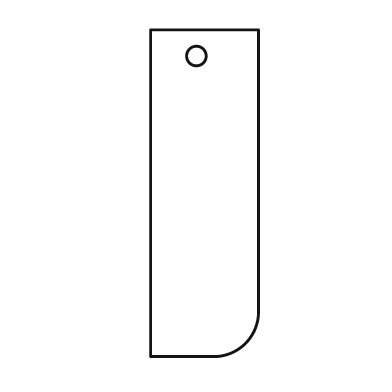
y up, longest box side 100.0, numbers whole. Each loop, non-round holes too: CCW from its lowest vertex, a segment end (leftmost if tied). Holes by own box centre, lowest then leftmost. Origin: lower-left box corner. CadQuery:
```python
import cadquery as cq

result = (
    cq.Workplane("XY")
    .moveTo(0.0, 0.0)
    .lineTo(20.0, 0.0)
    .threePointArc((29.0, 4.0), (33.0, 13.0))
    .lineTo(33.0, 100.0)
    .lineTo(0.0, 100.0)
    .close()
    .moveTo(14.0, 92.0)
    .circle(3.0)
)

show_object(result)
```